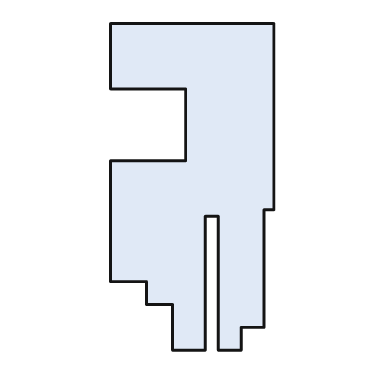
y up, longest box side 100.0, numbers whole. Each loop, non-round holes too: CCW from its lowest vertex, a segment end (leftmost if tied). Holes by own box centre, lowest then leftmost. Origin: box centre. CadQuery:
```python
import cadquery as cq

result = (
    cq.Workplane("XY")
    .moveTo(-6.0, -50.0)
    .lineTo(4.0, -50.0)
    .lineTo(4.0, -9.0)
    .lineTo(8.0, -9.0)
    .lineTo(8.0, -50.0)
    .lineTo(15.0, -50.0)
    .lineTo(15.0, -43.0)
    .lineTo(22.0, -43.0)
    .lineTo(22.0, -7.0)
    .lineTo(25.0, -7.0)
    .lineTo(25.0, 50.0)
    .lineTo(-25.0, 50.0)
    .lineTo(-25.0, 30.0)
    .lineTo(-2.0, 30.0)
    .lineTo(-2.0, 8.0)
    .lineTo(-25.0, 8.0)
    .lineTo(-25.0, -29.0)
    .lineTo(-14.0, -29.0)
    .lineTo(-14.0, -36.0)
    .lineTo(-6.0, -36.0)
    .close()
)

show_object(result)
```